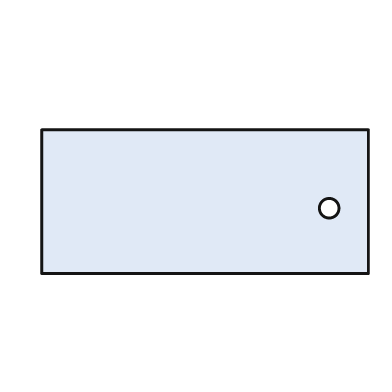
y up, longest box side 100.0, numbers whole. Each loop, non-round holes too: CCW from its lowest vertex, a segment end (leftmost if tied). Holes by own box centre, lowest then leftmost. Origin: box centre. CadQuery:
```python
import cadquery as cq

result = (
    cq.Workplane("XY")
    .moveTo(-50.0, -22.0)
    .lineTo(50.0, -22.0)
    .lineTo(50.0, 22.0)
    .lineTo(-50.0, 22.0)
    .close()
    .moveTo(38.0, -2.0)
    .circle(3.0)
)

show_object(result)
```